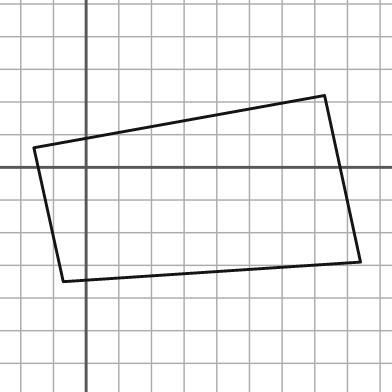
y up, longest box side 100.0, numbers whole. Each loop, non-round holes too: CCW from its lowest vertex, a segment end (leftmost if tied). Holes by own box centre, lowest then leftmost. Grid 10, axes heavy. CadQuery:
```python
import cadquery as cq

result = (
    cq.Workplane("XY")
    .moveTo(-7.0, -35.0)
    .lineTo(84.0, -29.0)
    .lineTo(73.0, 22.0)
    .lineTo(-16.0, 6.0)
    .close()
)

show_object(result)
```